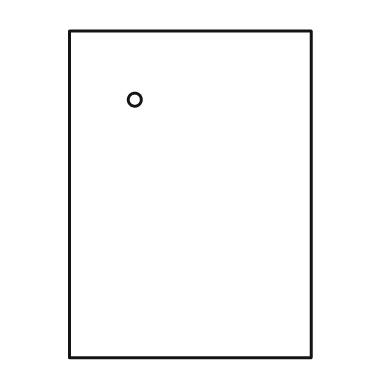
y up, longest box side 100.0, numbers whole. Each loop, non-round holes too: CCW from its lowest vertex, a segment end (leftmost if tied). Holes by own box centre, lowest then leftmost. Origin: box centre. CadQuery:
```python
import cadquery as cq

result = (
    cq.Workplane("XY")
    .moveTo(-37.0, -50.0)
    .lineTo(37.0, -50.0)
    .lineTo(37.0, 50.0)
    .lineTo(-37.0, 50.0)
    .close()
    .moveTo(-17.0, 29.0)
    .circle(2.0)
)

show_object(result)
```